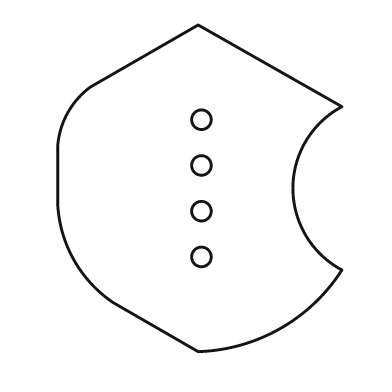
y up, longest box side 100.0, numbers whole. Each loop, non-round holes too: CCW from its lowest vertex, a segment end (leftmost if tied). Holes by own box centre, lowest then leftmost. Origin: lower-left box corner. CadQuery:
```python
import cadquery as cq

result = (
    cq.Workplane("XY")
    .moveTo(43.0, 0.0)
    .threePointArc((68.0, 7.0), (87.0, 25.0))
    .threePointArc((72.0, 50.0), (87.0, 75.0))
    .lineTo(43.0, 100.0)
    .lineTo(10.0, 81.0)
    .threePointArc((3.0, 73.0), (0.0, 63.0))
    .lineTo(0.0, 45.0)
    .threePointArc((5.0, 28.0), (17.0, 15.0))
    .close()
    .moveTo(44.0, 29.0)
    .circle(3.0)
    .moveTo(44.0, 43.0)
    .circle(3.0)
    .moveTo(44.0, 57.0)
    .circle(3.0)
    .moveTo(44.0, 71.0)
    .circle(3.0)
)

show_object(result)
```